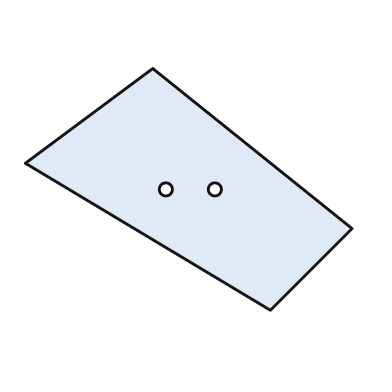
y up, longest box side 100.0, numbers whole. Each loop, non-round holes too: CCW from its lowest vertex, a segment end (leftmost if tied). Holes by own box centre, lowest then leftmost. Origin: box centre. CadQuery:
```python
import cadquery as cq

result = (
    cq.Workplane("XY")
    .moveTo(25.0, -37.0)
    .lineTo(50.0, -12.0)
    .lineTo(-11.0, 37.0)
    .lineTo(-50.0, 8.0)
    .close()
    .moveTo(-7.0, 0.0)
    .circle(2.0)
    .moveTo(8.0, 0.0)
    .circle(2.0)
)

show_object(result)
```